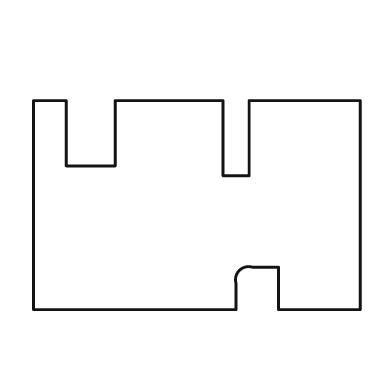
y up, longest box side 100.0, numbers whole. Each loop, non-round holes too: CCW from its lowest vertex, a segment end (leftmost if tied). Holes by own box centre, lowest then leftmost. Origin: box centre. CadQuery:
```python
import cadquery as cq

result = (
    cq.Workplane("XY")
    .moveTo(-50.0, -32.0)
    .lineTo(12.0, -32.0)
    .lineTo(12.0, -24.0)
    .threePointArc((13.0, -20.0), (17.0, -19.0))
    .lineTo(25.0, -19.0)
    .lineTo(25.0, -32.0)
    .lineTo(50.0, -32.0)
    .lineTo(50.0, 32.0)
    .lineTo(16.0, 32.0)
    .lineTo(16.0, 9.0)
    .lineTo(8.0, 9.0)
    .lineTo(8.0, 32.0)
    .lineTo(-25.0, 32.0)
    .lineTo(-25.0, 12.0)
    .lineTo(-40.0, 12.0)
    .lineTo(-40.0, 32.0)
    .lineTo(-50.0, 32.0)
    .close()
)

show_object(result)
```